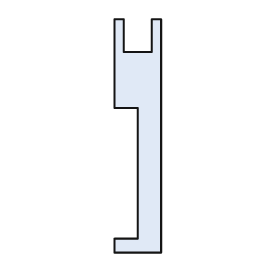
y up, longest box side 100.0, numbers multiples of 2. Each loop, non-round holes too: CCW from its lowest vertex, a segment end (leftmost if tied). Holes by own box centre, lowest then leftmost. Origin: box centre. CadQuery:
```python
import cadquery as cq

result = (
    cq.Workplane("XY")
    .moveTo(-10.0, -50.0)
    .lineTo(10.0, -50.0)
    .lineTo(10.0, 50.0)
    .lineTo(6.0, 50.0)
    .lineTo(6.0, 36.0)
    .lineTo(-6.0, 36.0)
    .lineTo(-6.0, 50.0)
    .lineTo(-10.0, 50.0)
    .lineTo(-10.0, 12.0)
    .lineTo(0.0, 12.0)
    .lineTo(0.0, -44.0)
    .lineTo(-10.0, -44.0)
    .close()
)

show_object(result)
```